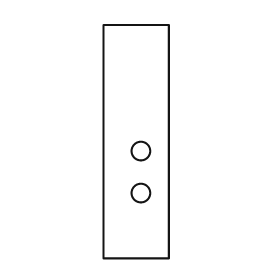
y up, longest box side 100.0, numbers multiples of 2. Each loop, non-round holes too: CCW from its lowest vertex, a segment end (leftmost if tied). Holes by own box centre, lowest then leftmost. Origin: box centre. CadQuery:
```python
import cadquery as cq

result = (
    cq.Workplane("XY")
    .moveTo(-14.0, -50.0)
    .lineTo(14.0, -50.0)
    .lineTo(14.0, 50.0)
    .lineTo(-14.0, 50.0)
    .close()
    .moveTo(2.0, -22.0)
    .circle(4.0)
    .moveTo(2.0, -4.0)
    .circle(4.0)
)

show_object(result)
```